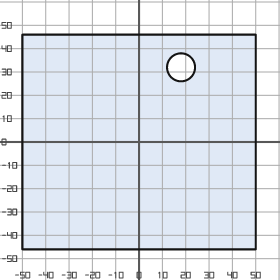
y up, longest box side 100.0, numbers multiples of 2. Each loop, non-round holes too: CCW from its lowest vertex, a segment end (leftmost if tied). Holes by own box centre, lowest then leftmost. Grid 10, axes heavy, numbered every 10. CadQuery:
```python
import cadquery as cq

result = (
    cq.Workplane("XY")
    .moveTo(-50.0, -46.0)
    .lineTo(50.0, -46.0)
    .lineTo(50.0, 46.0)
    .lineTo(-50.0, 46.0)
    .close()
    .moveTo(18.0, 32.0)
    .circle(6.0)
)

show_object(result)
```